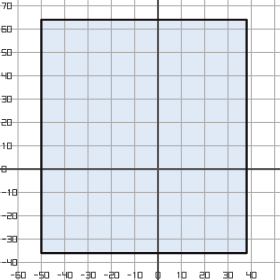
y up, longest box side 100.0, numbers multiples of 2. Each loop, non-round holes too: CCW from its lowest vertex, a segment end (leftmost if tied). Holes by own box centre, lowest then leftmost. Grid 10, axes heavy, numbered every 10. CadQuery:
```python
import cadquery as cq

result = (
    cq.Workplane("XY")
    .moveTo(-50.0, -36.0)
    .lineTo(38.0, -36.0)
    .lineTo(38.0, 64.0)
    .lineTo(-50.0, 64.0)
    .close()
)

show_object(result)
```